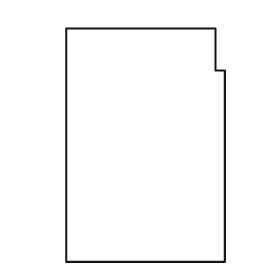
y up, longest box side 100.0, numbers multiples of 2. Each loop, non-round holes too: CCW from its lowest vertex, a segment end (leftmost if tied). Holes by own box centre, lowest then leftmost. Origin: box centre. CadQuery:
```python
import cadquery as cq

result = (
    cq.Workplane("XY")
    .moveTo(-34.0, -50.0)
    .lineTo(34.0, -50.0)
    .lineTo(34.0, 32.0)
    .lineTo(30.0, 32.0)
    .lineTo(30.0, 50.0)
    .lineTo(-34.0, 50.0)
    .close()
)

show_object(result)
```